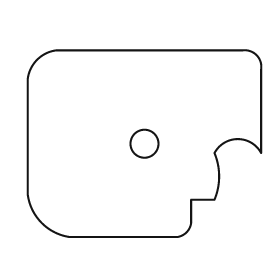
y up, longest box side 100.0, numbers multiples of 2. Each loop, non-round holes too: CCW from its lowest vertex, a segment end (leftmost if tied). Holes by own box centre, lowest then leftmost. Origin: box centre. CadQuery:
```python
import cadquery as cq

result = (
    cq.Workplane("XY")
    .moveTo(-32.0, -40.0)
    .lineTo(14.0, -40.0)
    .threePointArc((18.0, -38.0), (20.0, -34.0))
    .lineTo(20.0, -24.0)
    .lineTo(30.0, -24.0)
    .threePointArc((32.0, -14.0), (30.0, -4.0))
    .threePointArc((40.0, 2.0), (50.0, -4.0))
    .lineTo(50.0, 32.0)
    .threePointArc((48.0, 38.0), (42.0, 40.0))
    .lineTo(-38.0, 40.0)
    .threePointArc((-46.0, 36.0), (-50.0, 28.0))
    .lineTo(-50.0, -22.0)
    .threePointArc((-44.0, -34.0), (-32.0, -40.0))
    .close()
    .moveTo(0.0, 0.0)
    .circle(6.0)
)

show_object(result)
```